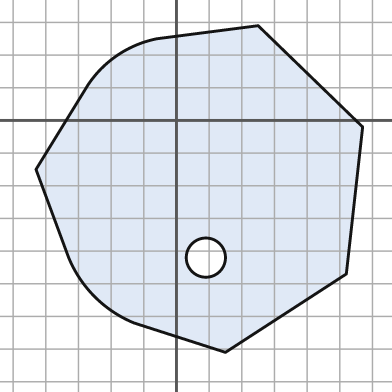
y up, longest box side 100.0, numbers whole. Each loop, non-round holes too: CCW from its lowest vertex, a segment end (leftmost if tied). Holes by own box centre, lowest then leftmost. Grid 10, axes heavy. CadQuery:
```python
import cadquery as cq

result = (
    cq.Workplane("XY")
    .moveTo(15.0, -71.0)
    .lineTo(52.0, -47.0)
    .lineTo(57.0, -2.0)
    .lineTo(25.0, 29.0)
    .lineTo(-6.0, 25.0)
    .threePointArc((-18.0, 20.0), (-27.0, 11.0))
    .lineTo(-43.0, -15.0)
    .lineTo(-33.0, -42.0)
    .threePointArc((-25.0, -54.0), (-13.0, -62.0))
    .close()
    .moveTo(9.0, -42.0)
    .circle(6.0)
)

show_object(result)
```